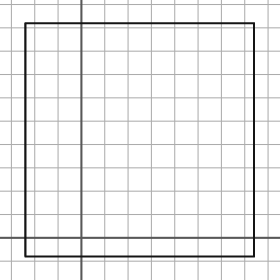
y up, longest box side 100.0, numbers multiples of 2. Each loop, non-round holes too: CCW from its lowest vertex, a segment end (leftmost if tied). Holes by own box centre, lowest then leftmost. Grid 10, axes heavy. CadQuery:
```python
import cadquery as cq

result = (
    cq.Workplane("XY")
    .moveTo(-24.0, -8.0)
    .lineTo(74.0, -8.0)
    .lineTo(74.0, 92.0)
    .lineTo(-24.0, 92.0)
    .close()
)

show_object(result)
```